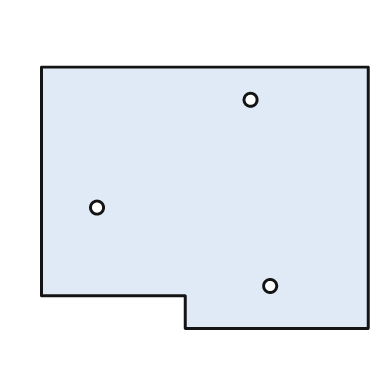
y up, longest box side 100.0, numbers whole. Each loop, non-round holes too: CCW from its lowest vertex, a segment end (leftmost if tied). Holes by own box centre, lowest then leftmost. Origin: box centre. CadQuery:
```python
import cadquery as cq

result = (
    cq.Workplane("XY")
    .moveTo(-6.0, -40.0)
    .lineTo(50.0, -40.0)
    .lineTo(50.0, 40.0)
    .lineTo(-50.0, 40.0)
    .lineTo(-50.0, -30.0)
    .lineTo(-6.0, -30.0)
    .close()
    .moveTo(20.0, -27.0)
    .circle(2.0)
    .moveTo(-33.0, -3.0)
    .circle(2.0)
    .moveTo(14.0, 30.0)
    .circle(2.0)
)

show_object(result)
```